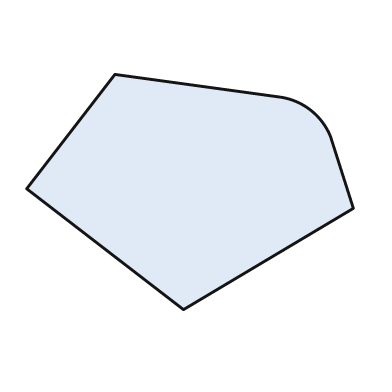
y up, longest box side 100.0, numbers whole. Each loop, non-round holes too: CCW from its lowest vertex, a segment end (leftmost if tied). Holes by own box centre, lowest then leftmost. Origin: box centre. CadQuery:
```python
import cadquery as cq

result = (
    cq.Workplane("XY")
    .moveTo(-2.0, -36.0)
    .lineTo(50.0, -5.0)
    .lineTo(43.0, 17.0)
    .threePointArc((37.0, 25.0), (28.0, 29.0))
    .lineTo(-23.0, 36.0)
    .lineTo(-50.0, 1.0)
    .close()
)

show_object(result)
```